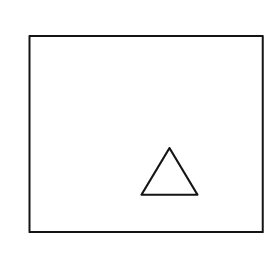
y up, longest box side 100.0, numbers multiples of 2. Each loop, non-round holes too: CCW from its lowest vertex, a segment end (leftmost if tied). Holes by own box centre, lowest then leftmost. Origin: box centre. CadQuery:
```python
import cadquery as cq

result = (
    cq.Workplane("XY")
    .moveTo(-50.0, -42.0)
    .lineTo(50.0, -42.0)
    .lineTo(50.0, 42.0)
    .lineTo(-50.0, 42.0)
    .close()
    .moveTo(-2.0, -26.0)
    .lineTo(22.0, -26.0)
    .lineTo(10.0, -6.0)
    .close()
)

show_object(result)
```